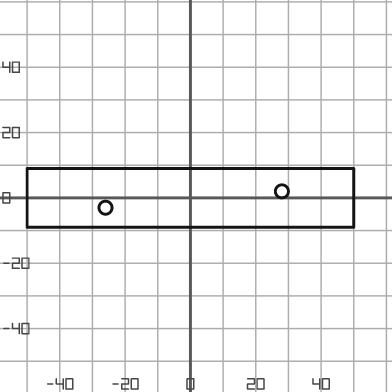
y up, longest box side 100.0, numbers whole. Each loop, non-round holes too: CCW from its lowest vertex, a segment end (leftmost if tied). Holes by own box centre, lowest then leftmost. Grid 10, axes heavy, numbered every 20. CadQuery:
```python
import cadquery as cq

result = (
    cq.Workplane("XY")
    .moveTo(-50.0, -9.0)
    .lineTo(50.0, -9.0)
    .lineTo(50.0, 9.0)
    .lineTo(-50.0, 9.0)
    .close()
    .moveTo(-26.0, -3.0)
    .circle(2.0)
    .moveTo(28.0, 2.0)
    .circle(2.0)
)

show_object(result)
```